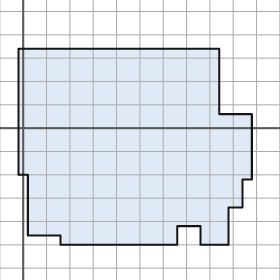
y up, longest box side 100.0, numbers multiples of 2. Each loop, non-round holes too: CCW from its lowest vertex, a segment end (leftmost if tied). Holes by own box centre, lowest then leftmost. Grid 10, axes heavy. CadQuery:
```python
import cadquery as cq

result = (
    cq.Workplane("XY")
    .moveTo(16.0, -50.0)
    .lineTo(66.0, -50.0)
    .lineTo(66.0, -42.0)
    .lineTo(76.0, -42.0)
    .lineTo(76.0, -50.0)
    .lineTo(88.0, -50.0)
    .lineTo(88.0, -34.0)
    .lineTo(94.0, -34.0)
    .lineTo(94.0, -22.0)
    .lineTo(98.0, -22.0)
    .lineTo(98.0, 6.0)
    .lineTo(84.0, 6.0)
    .lineTo(84.0, 34.0)
    .lineTo(-2.0, 34.0)
    .lineTo(-2.0, -20.0)
    .lineTo(2.0, -20.0)
    .lineTo(2.0, -46.0)
    .lineTo(16.0, -46.0)
    .close()
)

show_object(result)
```